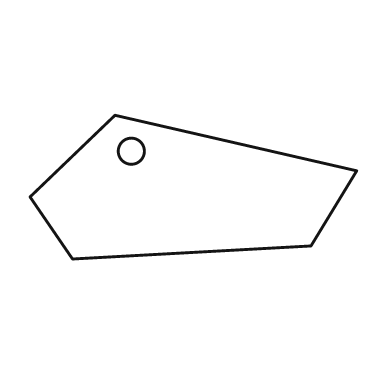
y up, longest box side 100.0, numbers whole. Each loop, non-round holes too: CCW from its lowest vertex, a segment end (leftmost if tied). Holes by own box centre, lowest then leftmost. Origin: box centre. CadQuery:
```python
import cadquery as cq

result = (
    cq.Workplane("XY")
    .moveTo(-37.0, -22.0)
    .lineTo(36.0, -18.0)
    .lineTo(50.0, 5.0)
    .lineTo(-24.0, 22.0)
    .lineTo(-50.0, -3.0)
    .close()
    .moveTo(-19.0, 11.0)
    .circle(4.0)
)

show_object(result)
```